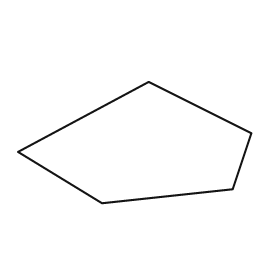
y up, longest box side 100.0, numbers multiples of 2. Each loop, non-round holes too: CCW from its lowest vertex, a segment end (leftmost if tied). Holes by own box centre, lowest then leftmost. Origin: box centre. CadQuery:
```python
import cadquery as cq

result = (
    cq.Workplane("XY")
    .moveTo(-14.0, -26.0)
    .lineTo(42.0, -20.0)
    .lineTo(50.0, 4.0)
    .lineTo(6.0, 26.0)
    .lineTo(-50.0, -4.0)
    .close()
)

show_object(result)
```